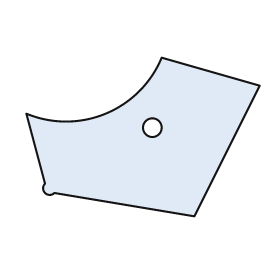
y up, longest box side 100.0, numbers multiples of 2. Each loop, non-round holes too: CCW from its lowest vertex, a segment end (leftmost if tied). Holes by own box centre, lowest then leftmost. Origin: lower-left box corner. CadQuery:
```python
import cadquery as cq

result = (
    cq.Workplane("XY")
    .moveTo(72.0, 0.0)
    .lineTo(100.0, 56.0)
    .lineTo(58.0, 68.0)
    .threePointArc((34.0, 44.0), (0.0, 44.0))
    .lineTo(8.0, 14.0)
    .threePointArc((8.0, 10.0), (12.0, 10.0))
    .close()
    .moveTo(54.0, 38.0)
    .circle(4.0)
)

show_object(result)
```